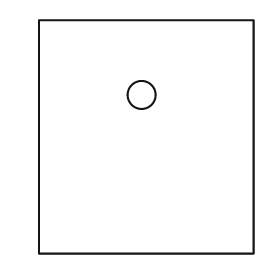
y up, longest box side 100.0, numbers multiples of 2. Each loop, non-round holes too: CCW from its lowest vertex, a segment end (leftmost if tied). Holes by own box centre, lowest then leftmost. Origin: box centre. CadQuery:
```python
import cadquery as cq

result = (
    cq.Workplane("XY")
    .moveTo(-46.0, -50.0)
    .lineTo(46.0, -50.0)
    .lineTo(46.0, 50.0)
    .lineTo(-46.0, 50.0)
    .close()
    .moveTo(-2.0, 18.0)
    .circle(6.0)
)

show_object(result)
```